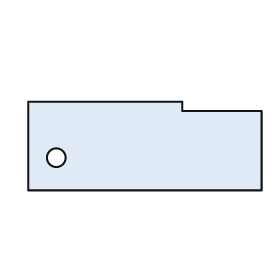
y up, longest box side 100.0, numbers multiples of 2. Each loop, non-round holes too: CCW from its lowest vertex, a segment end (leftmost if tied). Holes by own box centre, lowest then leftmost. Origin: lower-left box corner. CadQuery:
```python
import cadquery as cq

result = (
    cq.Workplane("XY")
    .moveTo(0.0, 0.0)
    .lineTo(100.0, 0.0)
    .lineTo(100.0, 34.0)
    .lineTo(66.0, 34.0)
    .lineTo(66.0, 38.0)
    .lineTo(0.0, 38.0)
    .close()
    .moveTo(12.0, 14.0)
    .circle(4.0)
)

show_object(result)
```